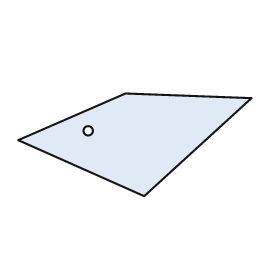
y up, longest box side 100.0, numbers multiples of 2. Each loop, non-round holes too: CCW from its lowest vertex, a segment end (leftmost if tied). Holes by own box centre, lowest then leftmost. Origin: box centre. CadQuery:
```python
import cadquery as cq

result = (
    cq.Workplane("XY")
    .moveTo(4.0, -22.0)
    .lineTo(50.0, 20.0)
    .lineTo(-4.0, 22.0)
    .lineTo(-50.0, 2.0)
    .close()
    .moveTo(-20.0, 6.0)
    .circle(2.0)
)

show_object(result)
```